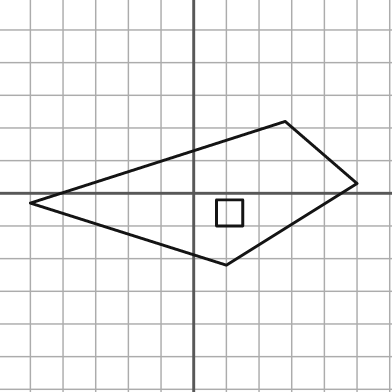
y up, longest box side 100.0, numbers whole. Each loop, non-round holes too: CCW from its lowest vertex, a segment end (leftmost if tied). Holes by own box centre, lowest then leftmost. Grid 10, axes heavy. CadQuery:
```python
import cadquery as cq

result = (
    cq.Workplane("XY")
    .moveTo(10.0, -22.0)
    .lineTo(50.0, 3.0)
    .lineTo(28.0, 22.0)
    .lineTo(-50.0, -3.0)
    .close()
    .moveTo(7.0, -10.0)
    .lineTo(15.0, -10.0)
    .lineTo(15.0, -2.0)
    .lineTo(7.0, -2.0)
    .close()
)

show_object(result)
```